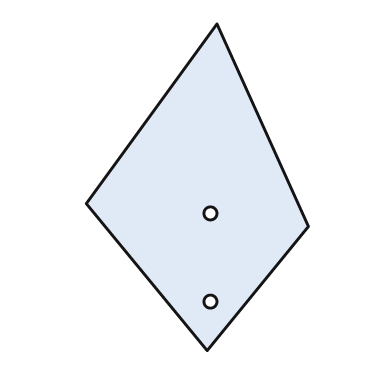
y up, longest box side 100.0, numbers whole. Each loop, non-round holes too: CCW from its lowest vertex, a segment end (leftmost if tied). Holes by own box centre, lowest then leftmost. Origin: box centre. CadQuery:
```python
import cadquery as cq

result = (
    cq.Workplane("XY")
    .moveTo(3.0, -50.0)
    .lineTo(34.0, -12.0)
    .lineTo(6.0, 50.0)
    .lineTo(-34.0, -5.0)
    .close()
    .moveTo(4.0, -35.0)
    .circle(2.0)
    .moveTo(4.0, -8.0)
    .circle(2.0)
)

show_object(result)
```